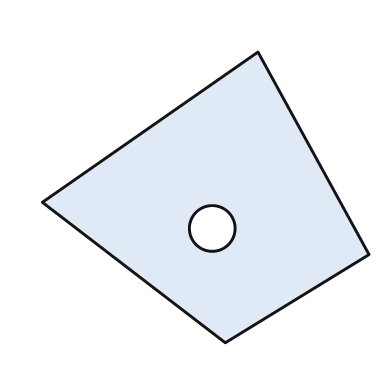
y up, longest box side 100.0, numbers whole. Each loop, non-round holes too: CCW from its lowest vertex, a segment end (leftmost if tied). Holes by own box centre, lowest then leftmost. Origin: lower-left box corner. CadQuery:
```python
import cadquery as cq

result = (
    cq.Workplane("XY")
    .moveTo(56.0, 0.0)
    .lineTo(100.0, 27.0)
    .lineTo(66.0, 89.0)
    .lineTo(0.0, 43.0)
    .close()
    .moveTo(52.0, 35.0)
    .circle(7.0)
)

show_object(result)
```